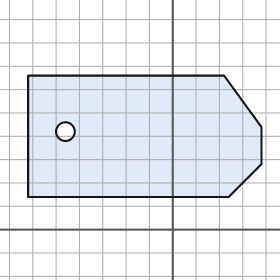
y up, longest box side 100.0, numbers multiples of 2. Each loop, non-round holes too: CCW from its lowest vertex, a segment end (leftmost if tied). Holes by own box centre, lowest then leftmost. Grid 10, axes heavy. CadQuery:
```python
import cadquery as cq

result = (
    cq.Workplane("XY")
    .moveTo(-62.0, 14.0)
    .lineTo(24.0, 14.0)
    .lineTo(38.0, 28.0)
    .lineTo(38.0, 44.0)
    .lineTo(22.0, 66.0)
    .lineTo(-62.0, 66.0)
    .close()
    .moveTo(-46.0, 42.0)
    .circle(4.0)
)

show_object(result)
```